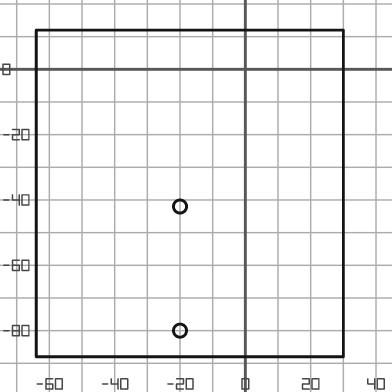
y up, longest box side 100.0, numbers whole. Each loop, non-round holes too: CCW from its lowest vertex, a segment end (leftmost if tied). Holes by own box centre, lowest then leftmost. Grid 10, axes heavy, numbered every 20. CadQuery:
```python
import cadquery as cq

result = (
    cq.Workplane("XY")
    .moveTo(-64.0, -88.0)
    .lineTo(30.0, -88.0)
    .lineTo(30.0, 12.0)
    .lineTo(-64.0, 12.0)
    .close()
    .moveTo(-20.0, -80.0)
    .circle(2.0)
    .moveTo(-20.0, -42.0)
    .circle(2.0)
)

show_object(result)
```